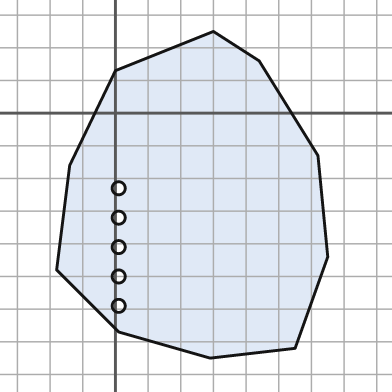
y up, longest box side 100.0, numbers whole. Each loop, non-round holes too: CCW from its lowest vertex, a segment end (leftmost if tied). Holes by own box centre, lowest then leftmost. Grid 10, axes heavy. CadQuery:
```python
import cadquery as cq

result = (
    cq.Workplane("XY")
    .moveTo(29.0, -75.0)
    .lineTo(55.0, -72.0)
    .lineTo(65.0, -44.0)
    .lineTo(62.0, -13.0)
    .lineTo(44.0, 16.0)
    .lineTo(30.0, 25.0)
    .lineTo(0.0, 13.0)
    .lineTo(-14.0, -16.0)
    .lineTo(-18.0, -48.0)
    .lineTo(1.0, -67.0)
    .close()
    .moveTo(1.0, -59.0)
    .circle(2.0)
    .moveTo(1.0, -50.0)
    .circle(2.0)
    .moveTo(1.0, -41.0)
    .circle(2.0)
    .moveTo(1.0, -32.0)
    .circle(2.0)
    .moveTo(1.0, -23.0)
    .circle(2.0)
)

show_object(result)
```